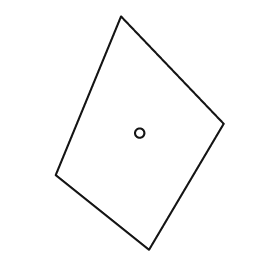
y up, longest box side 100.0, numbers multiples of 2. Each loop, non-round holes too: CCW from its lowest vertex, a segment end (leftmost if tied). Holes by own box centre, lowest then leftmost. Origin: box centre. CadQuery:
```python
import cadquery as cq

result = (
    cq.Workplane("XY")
    .moveTo(4.0, -50.0)
    .lineTo(36.0, 4.0)
    .lineTo(-8.0, 50.0)
    .lineTo(-36.0, -18.0)
    .close()
    .moveTo(0.0, 0.0)
    .circle(2.0)
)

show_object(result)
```